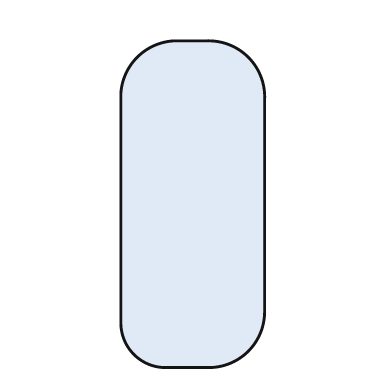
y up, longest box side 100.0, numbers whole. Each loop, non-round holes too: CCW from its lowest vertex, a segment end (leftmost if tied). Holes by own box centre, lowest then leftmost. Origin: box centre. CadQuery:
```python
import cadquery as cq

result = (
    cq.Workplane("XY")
    .moveTo(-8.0, -50.0)
    .lineTo(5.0, -50.0)
    .threePointArc((17.0, -45.0), (22.0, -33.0))
    .lineTo(22.0, 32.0)
    .threePointArc((17.0, 45.0), (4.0, 50.0))
    .lineTo(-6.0, 50.0)
    .threePointArc((-17.0, 45.0), (-22.0, 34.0))
    .lineTo(-22.0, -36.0)
    .threePointArc((-18.0, -46.0), (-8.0, -50.0))
    .close()
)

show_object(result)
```